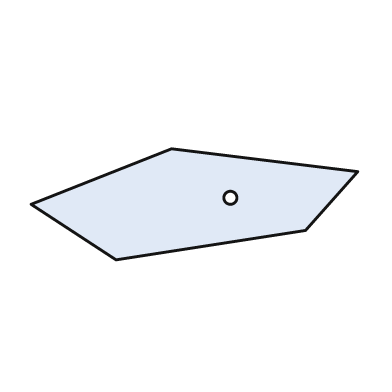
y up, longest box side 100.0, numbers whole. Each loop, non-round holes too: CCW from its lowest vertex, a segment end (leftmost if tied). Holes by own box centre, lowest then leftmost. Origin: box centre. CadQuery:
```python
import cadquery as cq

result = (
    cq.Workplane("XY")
    .moveTo(-24.0, -17.0)
    .lineTo(34.0, -8.0)
    .lineTo(50.0, 10.0)
    .lineTo(-7.0, 17.0)
    .lineTo(-50.0, 0.0)
    .close()
    .moveTo(11.0, 2.0)
    .circle(2.0)
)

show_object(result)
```